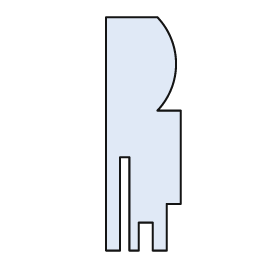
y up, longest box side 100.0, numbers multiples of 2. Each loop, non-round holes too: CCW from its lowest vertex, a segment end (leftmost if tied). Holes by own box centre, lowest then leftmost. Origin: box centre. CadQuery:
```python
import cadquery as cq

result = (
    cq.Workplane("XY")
    .moveTo(-16.0, -50.0)
    .lineTo(-10.0, -50.0)
    .lineTo(-10.0, -10.0)
    .lineTo(-6.0, -10.0)
    .lineTo(-6.0, -50.0)
    .lineTo(-2.0, -50.0)
    .lineTo(-2.0, -38.0)
    .lineTo(4.0, -38.0)
    .lineTo(4.0, -50.0)
    .lineTo(10.0, -50.0)
    .lineTo(10.0, -30.0)
    .lineTo(16.0, -30.0)
    .lineTo(16.0, 10.0)
    .lineTo(6.0, 10.0)
    .threePointArc((14.0, 30.0), (6.0, 50.0))
    .lineTo(-16.0, 50.0)
    .close()
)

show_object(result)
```